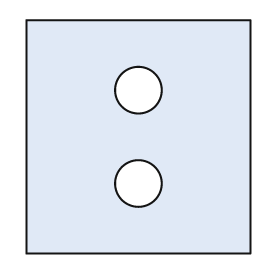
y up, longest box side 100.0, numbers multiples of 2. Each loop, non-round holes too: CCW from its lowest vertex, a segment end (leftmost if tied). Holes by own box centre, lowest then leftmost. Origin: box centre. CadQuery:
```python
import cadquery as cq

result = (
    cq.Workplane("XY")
    .moveTo(-48.0, -50.0)
    .lineTo(48.0, -50.0)
    .lineTo(48.0, 50.0)
    .lineTo(-48.0, 50.0)
    .close()
    .moveTo(0.0, -20.0)
    .circle(10.0)
    .moveTo(0.0, 20.0)
    .circle(10.0)
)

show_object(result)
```